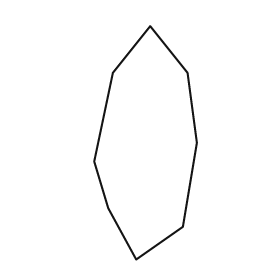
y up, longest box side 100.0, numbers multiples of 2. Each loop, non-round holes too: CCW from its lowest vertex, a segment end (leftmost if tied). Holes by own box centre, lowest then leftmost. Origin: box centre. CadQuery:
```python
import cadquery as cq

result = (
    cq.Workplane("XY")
    .moveTo(-4.0, -50.0)
    .lineTo(16.0, -36.0)
    .lineTo(22.0, 0.0)
    .lineTo(18.0, 30.0)
    .lineTo(2.0, 50.0)
    .lineTo(-14.0, 30.0)
    .lineTo(-22.0, -8.0)
    .lineTo(-16.0, -28.0)
    .close()
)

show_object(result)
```